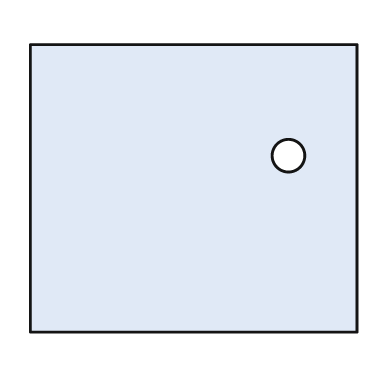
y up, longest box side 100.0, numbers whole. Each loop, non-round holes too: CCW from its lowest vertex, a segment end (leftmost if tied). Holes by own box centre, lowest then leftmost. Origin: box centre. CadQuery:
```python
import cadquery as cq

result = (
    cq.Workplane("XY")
    .moveTo(-50.0, -44.0)
    .lineTo(50.0, -44.0)
    .lineTo(50.0, 44.0)
    .lineTo(-50.0, 44.0)
    .close()
    .moveTo(29.0, 10.0)
    .circle(5.0)
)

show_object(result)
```